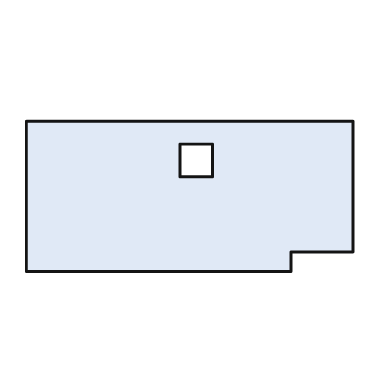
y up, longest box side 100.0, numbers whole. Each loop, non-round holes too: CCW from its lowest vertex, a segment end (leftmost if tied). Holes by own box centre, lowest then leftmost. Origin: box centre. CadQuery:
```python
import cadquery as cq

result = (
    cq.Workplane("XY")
    .moveTo(-50.0, -23.0)
    .lineTo(31.0, -23.0)
    .lineTo(31.0, -17.0)
    .lineTo(50.0, -17.0)
    .lineTo(50.0, 23.0)
    .lineTo(-50.0, 23.0)
    .close()
    .moveTo(-3.0, 6.0)
    .lineTo(7.0, 6.0)
    .lineTo(7.0, 16.0)
    .lineTo(-3.0, 16.0)
    .close()
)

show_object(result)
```